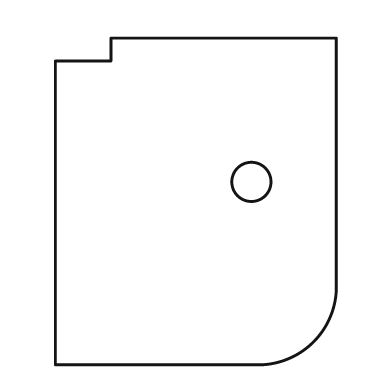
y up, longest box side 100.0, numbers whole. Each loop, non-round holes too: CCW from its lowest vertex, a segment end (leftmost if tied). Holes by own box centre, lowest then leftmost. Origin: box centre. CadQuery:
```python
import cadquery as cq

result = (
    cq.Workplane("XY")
    .moveTo(-43.0, -50.0)
    .lineTo(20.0, -50.0)
    .threePointArc((36.0, -43.0), (43.0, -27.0))
    .lineTo(43.0, 50.0)
    .lineTo(-26.0, 50.0)
    .lineTo(-26.0, 43.0)
    .lineTo(-43.0, 43.0)
    .close()
    .moveTo(17.0, 6.0)
    .circle(6.0)
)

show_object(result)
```